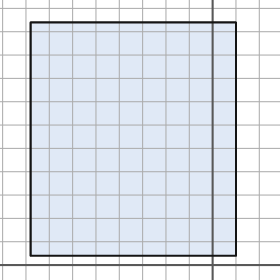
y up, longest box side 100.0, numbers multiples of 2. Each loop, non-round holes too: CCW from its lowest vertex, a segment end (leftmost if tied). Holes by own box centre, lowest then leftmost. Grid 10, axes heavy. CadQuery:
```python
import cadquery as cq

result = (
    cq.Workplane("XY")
    .moveTo(-78.0, 4.0)
    .lineTo(10.0, 4.0)
    .lineTo(10.0, 104.0)
    .lineTo(-78.0, 104.0)
    .close()
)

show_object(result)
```